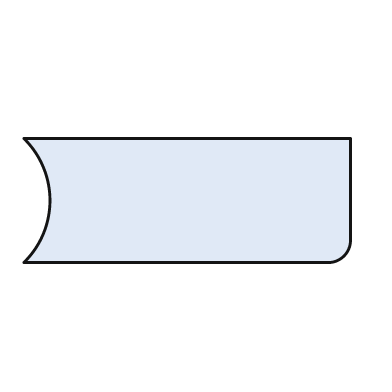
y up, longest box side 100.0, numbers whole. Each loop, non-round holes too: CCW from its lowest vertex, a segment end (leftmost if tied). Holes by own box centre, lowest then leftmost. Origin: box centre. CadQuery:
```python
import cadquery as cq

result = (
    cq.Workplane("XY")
    .moveTo(-50.0, -19.0)
    .lineTo(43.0, -19.0)
    .threePointArc((48.0, -17.0), (50.0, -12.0))
    .lineTo(50.0, 19.0)
    .lineTo(-50.0, 19.0)
    .threePointArc((-42.0, 0.0), (-50.0, -19.0))
    .close()
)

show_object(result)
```